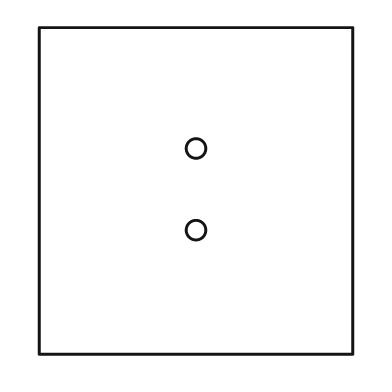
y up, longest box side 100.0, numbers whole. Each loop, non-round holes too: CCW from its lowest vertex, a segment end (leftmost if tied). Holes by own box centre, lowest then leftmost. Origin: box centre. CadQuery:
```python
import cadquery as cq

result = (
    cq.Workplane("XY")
    .moveTo(-48.0, -50.0)
    .lineTo(48.0, -50.0)
    .lineTo(48.0, 50.0)
    .lineTo(-48.0, 50.0)
    .close()
    .moveTo(0.0, -12.0)
    .circle(3.0)
    .moveTo(0.0, 13.0)
    .circle(3.0)
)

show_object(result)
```